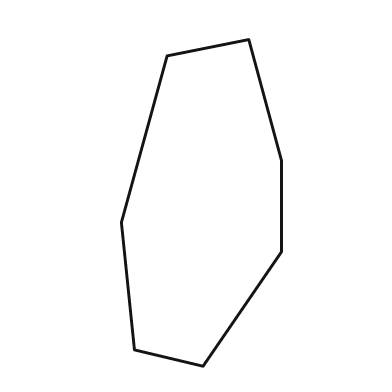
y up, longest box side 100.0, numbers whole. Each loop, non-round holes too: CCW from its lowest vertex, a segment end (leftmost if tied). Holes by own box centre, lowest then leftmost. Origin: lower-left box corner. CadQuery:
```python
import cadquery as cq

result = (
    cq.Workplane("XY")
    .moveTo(25.0, 0.0)
    .lineTo(49.0, 35.0)
    .lineTo(49.0, 63.0)
    .lineTo(39.0, 100.0)
    .lineTo(14.0, 95.0)
    .lineTo(0.0, 44.0)
    .lineTo(4.0, 5.0)
    .close()
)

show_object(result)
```